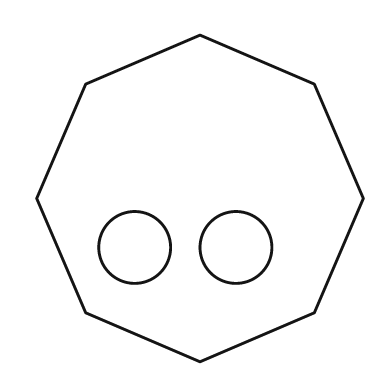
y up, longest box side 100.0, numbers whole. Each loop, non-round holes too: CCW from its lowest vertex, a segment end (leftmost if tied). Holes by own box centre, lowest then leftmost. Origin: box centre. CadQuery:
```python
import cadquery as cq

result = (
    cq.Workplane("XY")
    .moveTo(0.0, -50.0)
    .lineTo(35.0, -35.0)
    .lineTo(50.0, 0.0)
    .lineTo(35.0, 35.0)
    .lineTo(0.0, 50.0)
    .lineTo(-35.0, 35.0)
    .lineTo(-50.0, 0.0)
    .lineTo(-35.0, -35.0)
    .close()
    .moveTo(-20.0, -15.0)
    .circle(11.0)
    .moveTo(11.0, -15.0)
    .circle(11.0)
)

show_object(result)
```